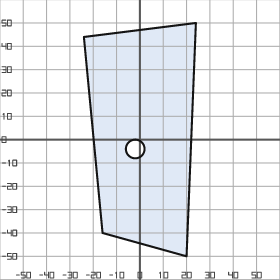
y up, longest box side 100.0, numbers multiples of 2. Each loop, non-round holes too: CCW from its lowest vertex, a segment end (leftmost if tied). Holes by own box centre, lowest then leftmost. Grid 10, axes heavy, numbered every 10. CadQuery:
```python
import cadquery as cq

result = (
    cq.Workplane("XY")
    .moveTo(20.0, -50.0)
    .lineTo(24.0, 50.0)
    .lineTo(-24.0, 44.0)
    .lineTo(-16.0, -40.0)
    .close()
    .moveTo(-2.0, -4.0)
    .circle(4.0)
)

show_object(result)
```